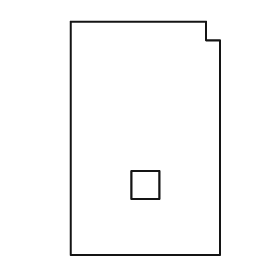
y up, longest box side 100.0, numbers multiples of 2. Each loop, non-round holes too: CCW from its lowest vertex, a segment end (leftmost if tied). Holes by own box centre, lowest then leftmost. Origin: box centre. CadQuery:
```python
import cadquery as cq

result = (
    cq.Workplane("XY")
    .moveTo(-32.0, -50.0)
    .lineTo(32.0, -50.0)
    .lineTo(32.0, 42.0)
    .lineTo(26.0, 42.0)
    .lineTo(26.0, 50.0)
    .lineTo(-32.0, 50.0)
    .close()
    .moveTo(-6.0, -26.0)
    .lineTo(6.0, -26.0)
    .lineTo(6.0, -14.0)
    .lineTo(-6.0, -14.0)
    .close()
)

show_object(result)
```